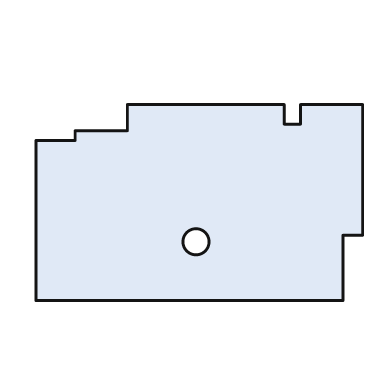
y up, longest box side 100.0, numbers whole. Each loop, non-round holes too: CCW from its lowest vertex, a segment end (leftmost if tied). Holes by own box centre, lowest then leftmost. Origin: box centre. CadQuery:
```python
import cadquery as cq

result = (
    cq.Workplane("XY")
    .moveTo(-50.0, -30.0)
    .lineTo(44.0, -30.0)
    .lineTo(44.0, -10.0)
    .lineTo(50.0, -10.0)
    .lineTo(50.0, 30.0)
    .lineTo(31.0, 30.0)
    .lineTo(31.0, 24.0)
    .lineTo(26.0, 24.0)
    .lineTo(26.0, 30.0)
    .lineTo(-22.0, 30.0)
    .lineTo(-22.0, 22.0)
    .lineTo(-38.0, 22.0)
    .lineTo(-38.0, 19.0)
    .lineTo(-50.0, 19.0)
    .close()
    .moveTo(-1.0, -12.0)
    .circle(4.0)
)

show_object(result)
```